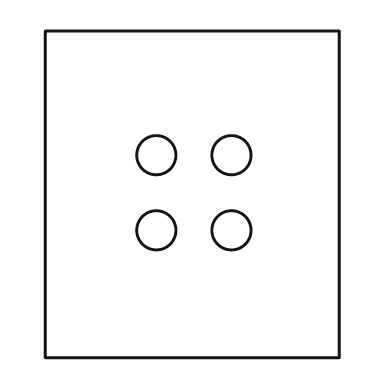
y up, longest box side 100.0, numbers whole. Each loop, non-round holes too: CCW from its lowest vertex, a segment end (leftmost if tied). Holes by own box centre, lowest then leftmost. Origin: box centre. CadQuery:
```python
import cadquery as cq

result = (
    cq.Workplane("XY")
    .moveTo(-45.0, -50.0)
    .lineTo(45.0, -50.0)
    .lineTo(45.0, 50.0)
    .lineTo(-45.0, 50.0)
    .close()
    .moveTo(-11.0, -11.0)
    .circle(6.0)
    .moveTo(12.0, -11.0)
    .circle(6.0)
    .moveTo(-11.0, 12.0)
    .circle(6.0)
    .moveTo(12.0, 12.0)
    .circle(6.0)
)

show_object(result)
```